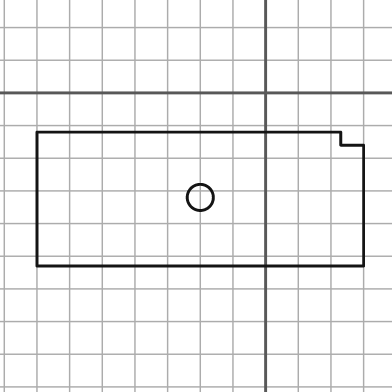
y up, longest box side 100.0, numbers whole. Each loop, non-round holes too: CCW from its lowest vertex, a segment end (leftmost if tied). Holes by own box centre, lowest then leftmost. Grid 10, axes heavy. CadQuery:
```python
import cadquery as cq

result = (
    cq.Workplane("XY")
    .moveTo(-70.0, -53.0)
    .lineTo(30.0, -53.0)
    .lineTo(30.0, -16.0)
    .lineTo(23.0, -16.0)
    .lineTo(23.0, -12.0)
    .lineTo(-70.0, -12.0)
    .close()
    .moveTo(-20.0, -32.0)
    .circle(4.0)
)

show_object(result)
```